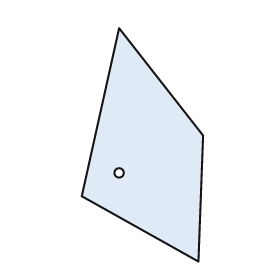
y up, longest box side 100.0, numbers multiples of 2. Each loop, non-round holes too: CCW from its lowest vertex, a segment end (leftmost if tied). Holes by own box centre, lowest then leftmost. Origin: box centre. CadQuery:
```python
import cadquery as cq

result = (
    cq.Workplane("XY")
    .moveTo(24.0, -50.0)
    .lineTo(26.0, 4.0)
    .lineTo(-10.0, 50.0)
    .lineTo(-26.0, -22.0)
    .close()
    .moveTo(-10.0, -12.0)
    .circle(2.0)
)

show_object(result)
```